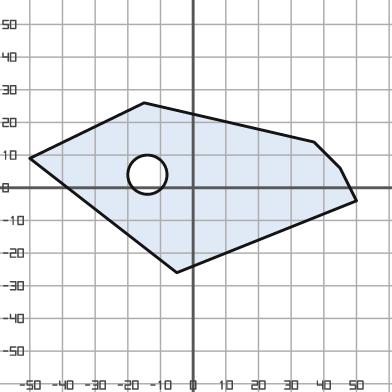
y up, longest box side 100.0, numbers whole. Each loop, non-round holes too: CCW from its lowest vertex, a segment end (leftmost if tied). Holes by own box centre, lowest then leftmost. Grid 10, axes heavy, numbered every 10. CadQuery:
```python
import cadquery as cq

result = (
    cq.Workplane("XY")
    .moveTo(-5.0, -26.0)
    .lineTo(50.0, -4.0)
    .lineTo(45.0, 6.0)
    .lineTo(37.0, 14.0)
    .lineTo(-15.0, 26.0)
    .lineTo(-50.0, 9.0)
    .close()
    .moveTo(-14.0, 4.0)
    .circle(6.0)
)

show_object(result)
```